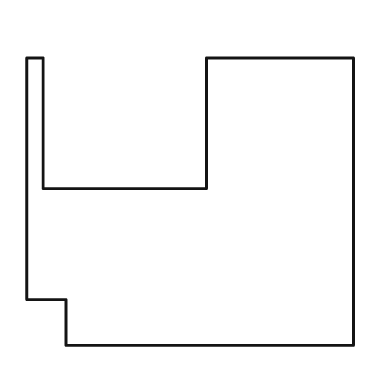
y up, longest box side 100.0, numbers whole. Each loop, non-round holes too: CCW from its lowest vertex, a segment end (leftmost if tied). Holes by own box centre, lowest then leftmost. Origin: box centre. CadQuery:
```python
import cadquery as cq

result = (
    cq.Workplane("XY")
    .moveTo(-38.0, -44.0)
    .lineTo(50.0, -44.0)
    .lineTo(50.0, 44.0)
    .lineTo(5.0, 44.0)
    .lineTo(5.0, 4.0)
    .lineTo(-45.0, 4.0)
    .lineTo(-45.0, 44.0)
    .lineTo(-50.0, 44.0)
    .lineTo(-50.0, -30.0)
    .lineTo(-38.0, -30.0)
    .close()
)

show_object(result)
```